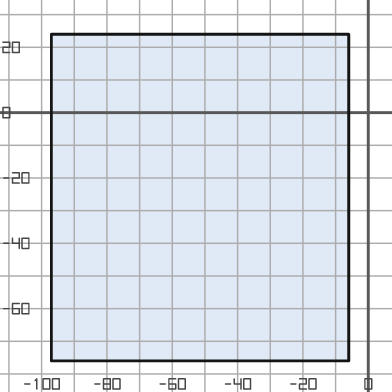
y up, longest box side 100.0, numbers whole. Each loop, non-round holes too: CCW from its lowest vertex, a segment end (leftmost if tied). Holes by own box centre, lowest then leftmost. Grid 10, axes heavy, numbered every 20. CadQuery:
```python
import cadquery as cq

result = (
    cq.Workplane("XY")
    .moveTo(-97.0, -76.0)
    .lineTo(-6.0, -76.0)
    .lineTo(-6.0, 24.0)
    .lineTo(-97.0, 24.0)
    .close()
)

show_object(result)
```